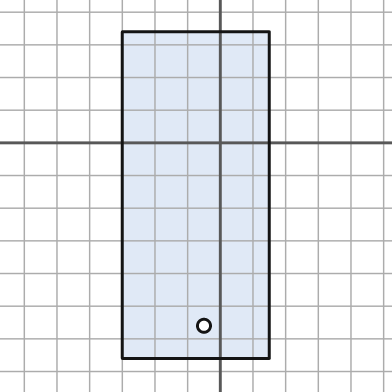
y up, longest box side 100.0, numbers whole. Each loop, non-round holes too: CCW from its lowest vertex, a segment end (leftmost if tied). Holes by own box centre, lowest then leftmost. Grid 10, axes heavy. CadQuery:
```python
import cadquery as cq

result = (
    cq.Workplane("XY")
    .moveTo(-30.0, -66.0)
    .lineTo(15.0, -66.0)
    .lineTo(15.0, 34.0)
    .lineTo(-30.0, 34.0)
    .close()
    .moveTo(-5.0, -56.0)
    .circle(2.0)
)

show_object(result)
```